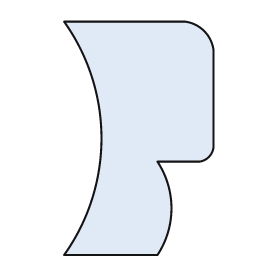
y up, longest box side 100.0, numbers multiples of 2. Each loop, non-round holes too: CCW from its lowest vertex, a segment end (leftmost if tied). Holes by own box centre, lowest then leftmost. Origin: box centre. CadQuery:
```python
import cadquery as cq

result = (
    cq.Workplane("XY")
    .moveTo(-32.0, -50.0)
    .lineTo(8.0, -50.0)
    .threePointArc((14.0, -30.0), (8.0, -10.0))
    .lineTo(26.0, -10.0)
    .threePointArc((30.0, -8.0), (32.0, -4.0))
    .lineTo(32.0, 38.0)
    .threePointArc((28.0, 46.0), (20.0, 50.0))
    .lineTo(-32.0, 50.0)
    .threePointArc((-16.0, 0.0), (-32.0, -50.0))
    .close()
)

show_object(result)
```